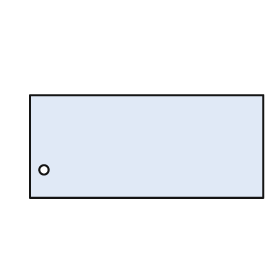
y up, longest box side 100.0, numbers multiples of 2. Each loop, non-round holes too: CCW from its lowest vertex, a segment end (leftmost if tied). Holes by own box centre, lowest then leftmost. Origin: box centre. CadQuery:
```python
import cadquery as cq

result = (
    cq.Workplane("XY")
    .moveTo(-50.0, -22.0)
    .lineTo(50.0, -22.0)
    .lineTo(50.0, 22.0)
    .lineTo(-50.0, 22.0)
    .close()
    .moveTo(-44.0, -10.0)
    .circle(2.0)
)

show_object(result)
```